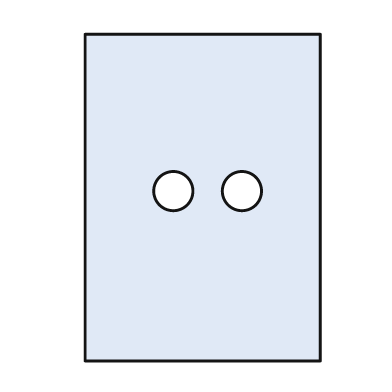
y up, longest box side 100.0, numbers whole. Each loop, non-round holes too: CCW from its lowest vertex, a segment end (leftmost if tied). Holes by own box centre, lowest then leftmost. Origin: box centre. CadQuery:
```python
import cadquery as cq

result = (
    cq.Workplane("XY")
    .moveTo(-36.0, -50.0)
    .lineTo(36.0, -50.0)
    .lineTo(36.0, 50.0)
    .lineTo(-36.0, 50.0)
    .close()
    .moveTo(-9.0, 2.0)
    .circle(6.0)
    .moveTo(12.0, 2.0)
    .circle(6.0)
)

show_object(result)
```